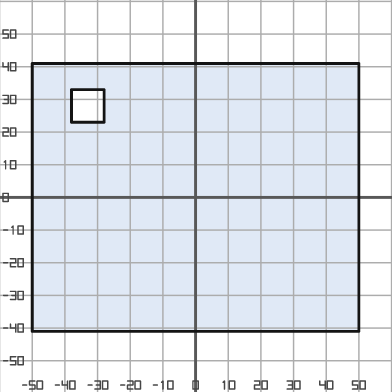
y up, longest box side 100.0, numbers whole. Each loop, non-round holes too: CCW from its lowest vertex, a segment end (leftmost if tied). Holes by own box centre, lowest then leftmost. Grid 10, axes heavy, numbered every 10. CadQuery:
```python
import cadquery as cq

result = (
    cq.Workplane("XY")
    .moveTo(-50.0, -41.0)
    .lineTo(50.0, -41.0)
    .lineTo(50.0, 41.0)
    .lineTo(-50.0, 41.0)
    .close()
    .moveTo(-38.0, 23.0)
    .lineTo(-28.0, 23.0)
    .lineTo(-28.0, 33.0)
    .lineTo(-38.0, 33.0)
    .close()
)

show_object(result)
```